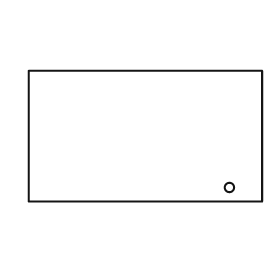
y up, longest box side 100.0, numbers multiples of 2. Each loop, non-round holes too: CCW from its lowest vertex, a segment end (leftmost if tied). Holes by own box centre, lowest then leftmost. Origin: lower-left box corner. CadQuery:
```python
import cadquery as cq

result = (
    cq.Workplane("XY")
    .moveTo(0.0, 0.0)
    .lineTo(100.0, 0.0)
    .lineTo(100.0, 56.0)
    .lineTo(0.0, 56.0)
    .close()
    .moveTo(86.0, 6.0)
    .circle(2.0)
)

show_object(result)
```